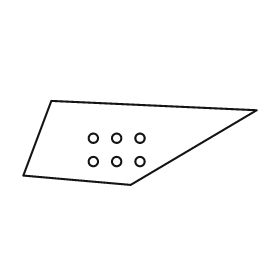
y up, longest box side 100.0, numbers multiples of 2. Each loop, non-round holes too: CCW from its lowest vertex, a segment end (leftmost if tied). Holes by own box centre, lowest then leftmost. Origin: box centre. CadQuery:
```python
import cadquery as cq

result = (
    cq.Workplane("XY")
    .moveTo(-4.0, -18.0)
    .lineTo(50.0, 14.0)
    .lineTo(-38.0, 18.0)
    .lineTo(-50.0, -14.0)
    .close()
    .moveTo(-20.0, -8.0)
    .circle(2.0)
    .moveTo(-10.0, -8.0)
    .circle(2.0)
    .moveTo(0.0, -8.0)
    .circle(2.0)
    .moveTo(-20.0, 2.0)
    .circle(2.0)
    .moveTo(-10.0, 2.0)
    .circle(2.0)
    .moveTo(0.0, 2.0)
    .circle(2.0)
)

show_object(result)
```